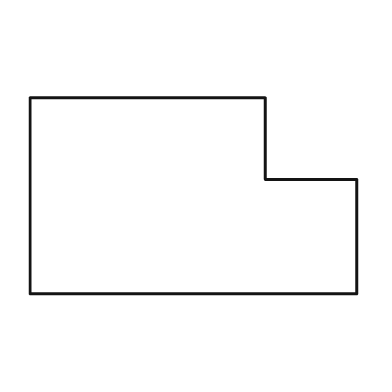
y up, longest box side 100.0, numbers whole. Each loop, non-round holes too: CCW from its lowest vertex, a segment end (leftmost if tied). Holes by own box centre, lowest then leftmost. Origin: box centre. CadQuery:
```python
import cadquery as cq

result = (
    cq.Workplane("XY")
    .moveTo(-50.0, -30.0)
    .lineTo(50.0, -30.0)
    .lineTo(50.0, 5.0)
    .lineTo(22.0, 5.0)
    .lineTo(22.0, 30.0)
    .lineTo(-50.0, 30.0)
    .close()
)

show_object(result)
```